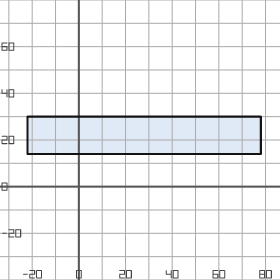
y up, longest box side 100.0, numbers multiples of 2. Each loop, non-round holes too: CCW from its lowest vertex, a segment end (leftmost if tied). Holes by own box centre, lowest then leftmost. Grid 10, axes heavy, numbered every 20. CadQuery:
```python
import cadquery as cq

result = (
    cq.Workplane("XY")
    .moveTo(-22.0, 14.0)
    .lineTo(78.0, 14.0)
    .lineTo(78.0, 30.0)
    .lineTo(-22.0, 30.0)
    .close()
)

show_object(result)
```